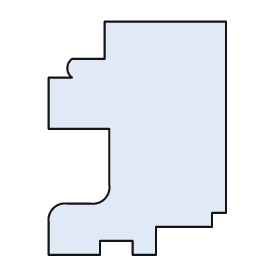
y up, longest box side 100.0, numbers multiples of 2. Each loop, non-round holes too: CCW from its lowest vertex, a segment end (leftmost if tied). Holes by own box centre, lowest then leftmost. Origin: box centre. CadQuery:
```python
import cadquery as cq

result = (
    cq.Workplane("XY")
    .moveTo(-38.0, -50.0)
    .lineTo(-16.0, -50.0)
    .lineTo(-16.0, -44.0)
    .lineTo(-2.0, -44.0)
    .lineTo(-2.0, -50.0)
    .lineTo(8.0, -50.0)
    .lineTo(8.0, -38.0)
    .lineTo(32.0, -38.0)
    .lineTo(32.0, -32.0)
    .lineTo(38.0, -32.0)
    .lineTo(38.0, 50.0)
    .lineTo(-14.0, 50.0)
    .lineTo(-14.0, 34.0)
    .lineTo(-28.0, 34.0)
    .threePointArc((-30.0, 30.0), (-28.0, 26.0))
    .lineTo(-38.0, 26.0)
    .lineTo(-38.0, 4.0)
    .lineTo(-12.0, 4.0)
    .lineTo(-12.0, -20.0)
    .threePointArc((-14.0, -26.0), (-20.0, -28.0))
    .lineTo(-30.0, -28.0)
    .threePointArc((-36.0, -30.0), (-38.0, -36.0))
    .close()
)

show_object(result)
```